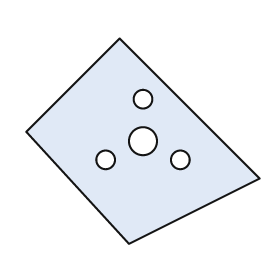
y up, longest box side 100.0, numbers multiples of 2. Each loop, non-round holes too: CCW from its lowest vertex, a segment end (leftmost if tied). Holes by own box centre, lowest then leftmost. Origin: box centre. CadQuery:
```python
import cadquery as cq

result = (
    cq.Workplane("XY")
    .moveTo(-6.0, -44.0)
    .lineTo(50.0, -16.0)
    .lineTo(-10.0, 44.0)
    .lineTo(-50.0, 4.0)
    .close()
    .moveTo(-16.0, -8.0)
    .circle(4.0)
    .moveTo(16.0, -8.0)
    .circle(4.0)
    .moveTo(0.0, 0.0)
    .circle(6.0)
    .moveTo(0.0, 18.0)
    .circle(4.0)
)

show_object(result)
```